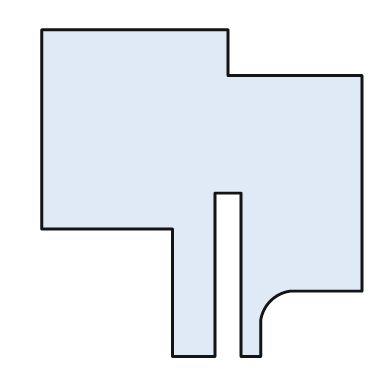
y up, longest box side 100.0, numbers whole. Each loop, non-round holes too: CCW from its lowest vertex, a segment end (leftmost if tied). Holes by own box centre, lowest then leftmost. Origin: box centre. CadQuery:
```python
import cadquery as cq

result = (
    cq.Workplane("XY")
    .moveTo(-9.0, -50.0)
    .lineTo(4.0, -50.0)
    .lineTo(4.0, 0.0)
    .lineTo(12.0, 0.0)
    .lineTo(12.0, -50.0)
    .lineTo(18.0, -50.0)
    .lineTo(18.0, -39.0)
    .threePointArc((21.0, -33.0), (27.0, -30.0))
    .lineTo(49.0, -30.0)
    .lineTo(49.0, 36.0)
    .lineTo(8.0, 36.0)
    .lineTo(8.0, 50.0)
    .lineTo(-49.0, 50.0)
    .lineTo(-49.0, -11.0)
    .lineTo(-9.0, -11.0)
    .close()
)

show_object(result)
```